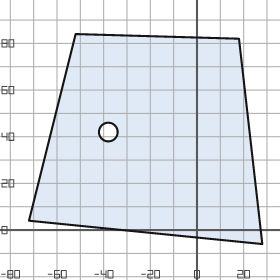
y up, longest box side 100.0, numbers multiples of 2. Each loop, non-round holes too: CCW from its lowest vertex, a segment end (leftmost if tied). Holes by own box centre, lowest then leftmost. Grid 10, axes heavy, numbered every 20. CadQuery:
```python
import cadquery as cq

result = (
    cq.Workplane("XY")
    .moveTo(28.0, -6.0)
    .lineTo(18.0, 82.0)
    .lineTo(-52.0, 84.0)
    .lineTo(-72.0, 4.0)
    .close()
    .moveTo(-38.0, 42.0)
    .circle(4.0)
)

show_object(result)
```